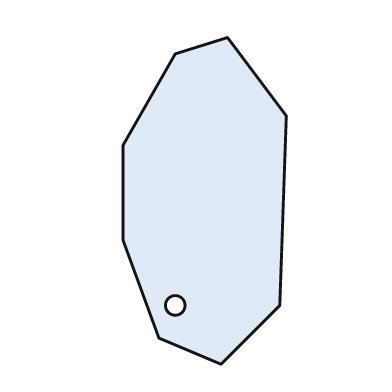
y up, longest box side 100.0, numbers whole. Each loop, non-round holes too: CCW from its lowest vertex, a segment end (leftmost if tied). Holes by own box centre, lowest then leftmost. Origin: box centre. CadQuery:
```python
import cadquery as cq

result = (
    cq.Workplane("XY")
    .moveTo(5.0, -50.0)
    .lineTo(23.0, -32.0)
    .lineTo(25.0, 26.0)
    .lineTo(7.0, 50.0)
    .lineTo(-9.0, 45.0)
    .lineTo(-25.0, 17.0)
    .lineTo(-25.0, -12.0)
    .lineTo(-14.0, -42.0)
    .close()
    .moveTo(-9.0, -32.0)
    .circle(3.0)
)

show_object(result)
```